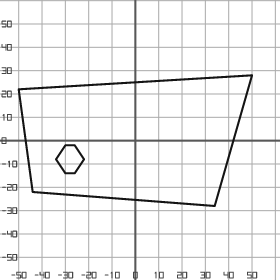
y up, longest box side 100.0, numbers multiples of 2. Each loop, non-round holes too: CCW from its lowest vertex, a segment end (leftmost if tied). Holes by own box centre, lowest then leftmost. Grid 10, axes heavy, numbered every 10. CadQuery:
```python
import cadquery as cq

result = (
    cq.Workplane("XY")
    .moveTo(34.0, -28.0)
    .lineTo(50.0, 28.0)
    .lineTo(-50.0, 22.0)
    .lineTo(-44.0, -22.0)
    .close()
    .moveTo(-30.0, -14.0)
    .lineTo(-26.0, -14.0)
    .lineTo(-22.0, -8.0)
    .lineTo(-26.0, -2.0)
    .lineTo(-30.0, -2.0)
    .lineTo(-34.0, -8.0)
    .close()
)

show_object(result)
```